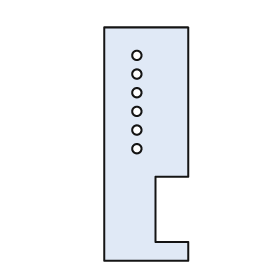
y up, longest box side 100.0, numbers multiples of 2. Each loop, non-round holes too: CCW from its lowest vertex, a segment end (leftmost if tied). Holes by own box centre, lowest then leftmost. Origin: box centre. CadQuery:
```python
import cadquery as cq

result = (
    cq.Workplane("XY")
    .moveTo(-18.0, -50.0)
    .lineTo(18.0, -50.0)
    .lineTo(18.0, -42.0)
    .lineTo(4.0, -42.0)
    .lineTo(4.0, -14.0)
    .lineTo(18.0, -14.0)
    .lineTo(18.0, 50.0)
    .lineTo(-18.0, 50.0)
    .close()
    .moveTo(-4.0, -2.0)
    .circle(2.0)
    .moveTo(-4.0, 6.0)
    .circle(2.0)
    .moveTo(-4.0, 14.0)
    .circle(2.0)
    .moveTo(-4.0, 22.0)
    .circle(2.0)
    .moveTo(-4.0, 30.0)
    .circle(2.0)
    .moveTo(-4.0, 38.0)
    .circle(2.0)
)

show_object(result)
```